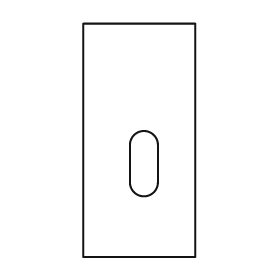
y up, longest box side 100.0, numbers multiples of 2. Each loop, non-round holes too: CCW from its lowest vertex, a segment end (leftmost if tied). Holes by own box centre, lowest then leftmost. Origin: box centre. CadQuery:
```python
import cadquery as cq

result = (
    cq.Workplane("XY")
    .moveTo(-24.0, -50.0)
    .lineTo(24.0, -50.0)
    .lineTo(24.0, 50.0)
    .lineTo(-24.0, 50.0)
    .close()
    .moveTo(-4.0, -18.0)
    .threePointArc((2.0, -24.0), (8.0, -18.0))
    .lineTo(8.0, -2.0)
    .threePointArc((2.0, 4.0), (-4.0, -2.0))
    .close()
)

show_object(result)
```